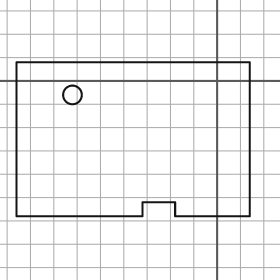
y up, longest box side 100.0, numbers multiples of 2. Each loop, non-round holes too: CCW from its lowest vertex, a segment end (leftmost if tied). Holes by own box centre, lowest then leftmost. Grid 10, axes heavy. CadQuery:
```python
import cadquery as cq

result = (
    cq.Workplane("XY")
    .moveTo(-86.0, -58.0)
    .lineTo(-32.0, -58.0)
    .lineTo(-32.0, -52.0)
    .lineTo(-18.0, -52.0)
    .lineTo(-18.0, -58.0)
    .lineTo(14.0, -58.0)
    .lineTo(14.0, 8.0)
    .lineTo(-86.0, 8.0)
    .close()
    .moveTo(-62.0, -6.0)
    .circle(4.0)
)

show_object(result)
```